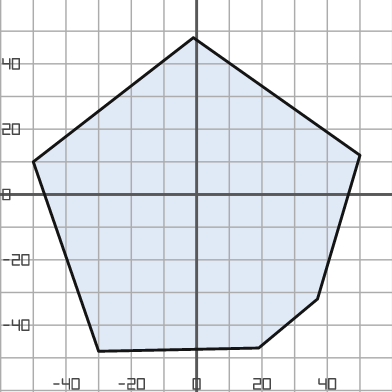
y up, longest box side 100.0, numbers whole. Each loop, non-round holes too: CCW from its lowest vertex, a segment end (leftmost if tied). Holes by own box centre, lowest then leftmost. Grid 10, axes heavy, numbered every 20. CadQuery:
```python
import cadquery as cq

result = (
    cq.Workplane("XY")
    .moveTo(-30.0, -48.0)
    .lineTo(19.0, -47.0)
    .lineTo(37.0, -32.0)
    .lineTo(50.0, 12.0)
    .lineTo(-1.0, 48.0)
    .lineTo(-50.0, 10.0)
    .close()
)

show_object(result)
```